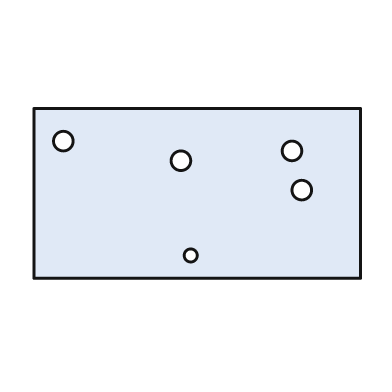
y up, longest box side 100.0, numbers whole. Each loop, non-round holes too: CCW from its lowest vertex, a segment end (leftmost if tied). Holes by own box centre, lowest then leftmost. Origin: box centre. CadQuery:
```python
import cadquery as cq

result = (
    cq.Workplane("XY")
    .moveTo(-50.0, -26.0)
    .lineTo(50.0, -26.0)
    .lineTo(50.0, 26.0)
    .lineTo(-50.0, 26.0)
    .close()
    .moveTo(-2.0, -19.0)
    .circle(2.0)
    .moveTo(32.0, 1.0)
    .circle(3.0)
    .moveTo(-5.0, 10.0)
    .circle(3.0)
    .moveTo(29.0, 13.0)
    .circle(3.0)
    .moveTo(-41.0, 16.0)
    .circle(3.0)
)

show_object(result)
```